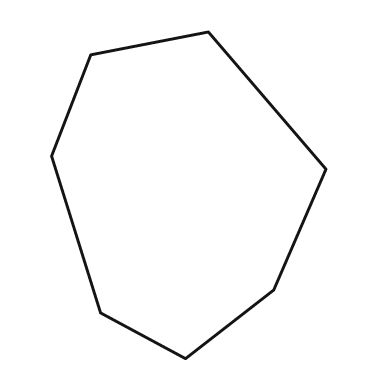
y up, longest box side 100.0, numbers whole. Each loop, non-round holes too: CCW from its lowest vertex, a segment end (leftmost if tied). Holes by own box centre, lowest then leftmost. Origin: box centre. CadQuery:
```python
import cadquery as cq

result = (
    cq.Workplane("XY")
    .moveTo(-1.0, -50.0)
    .lineTo(26.0, -29.0)
    .lineTo(42.0, 8.0)
    .lineTo(6.0, 50.0)
    .lineTo(-30.0, 43.0)
    .lineTo(-42.0, 12.0)
    .lineTo(-27.0, -36.0)
    .close()
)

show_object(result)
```